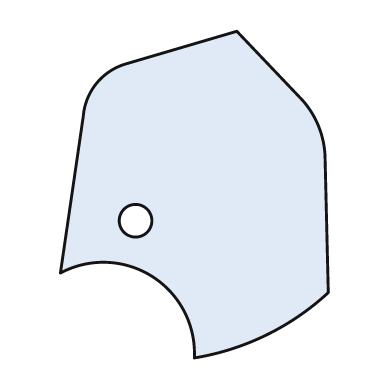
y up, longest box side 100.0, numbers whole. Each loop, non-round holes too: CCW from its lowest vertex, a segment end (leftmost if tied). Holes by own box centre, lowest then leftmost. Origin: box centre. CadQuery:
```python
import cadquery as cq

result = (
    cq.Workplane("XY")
    .moveTo(0.0, -50.0)
    .threePointArc((22.0, -43.0), (41.0, -30.0))
    .lineTo(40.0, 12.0)
    .threePointArc((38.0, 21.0), (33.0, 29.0))
    .lineTo(13.0, 50.0)
    .lineTo(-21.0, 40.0)
    .threePointArc((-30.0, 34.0), (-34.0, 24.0))
    .lineTo(-41.0, -24.0)
    .threePointArc((-13.0, -25.0), (0.0, -50.0))
    .close()
    .moveTo(-18.0, -8.0)
    .circle(5.0)
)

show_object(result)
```